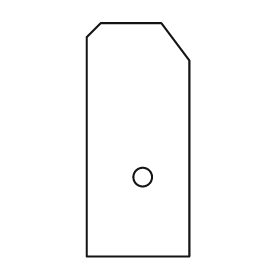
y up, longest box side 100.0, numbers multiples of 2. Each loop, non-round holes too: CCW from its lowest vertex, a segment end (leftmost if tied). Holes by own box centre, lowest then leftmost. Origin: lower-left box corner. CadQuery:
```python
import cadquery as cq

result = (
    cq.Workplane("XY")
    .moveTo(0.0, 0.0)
    .lineTo(44.0, 0.0)
    .lineTo(44.0, 84.0)
    .lineTo(32.0, 100.0)
    .lineTo(6.0, 100.0)
    .lineTo(0.0, 94.0)
    .close()
    .moveTo(24.0, 34.0)
    .circle(4.0)
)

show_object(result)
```